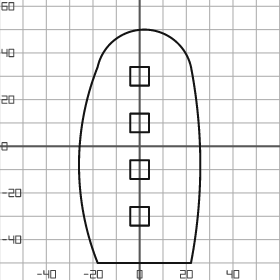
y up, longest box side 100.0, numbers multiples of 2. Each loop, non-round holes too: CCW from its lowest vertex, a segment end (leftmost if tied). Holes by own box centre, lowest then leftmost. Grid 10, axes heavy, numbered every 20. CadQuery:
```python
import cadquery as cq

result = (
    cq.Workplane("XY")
    .moveTo(-18.0, -50.0)
    .lineTo(22.0, -50.0)
    .threePointArc((26.0, -8.0), (22.0, 34.0))
    .threePointArc((2.0, 50.0), (-18.0, 34.0))
    .threePointArc((-26.0, -8.0), (-18.0, -50.0))
    .close()
    .moveTo(-4.0, -34.0)
    .lineTo(4.0, -34.0)
    .lineTo(4.0, -26.0)
    .lineTo(-4.0, -26.0)
    .close()
    .moveTo(-4.0, -14.0)
    .lineTo(4.0, -14.0)
    .lineTo(4.0, -6.0)
    .lineTo(-4.0, -6.0)
    .close()
    .moveTo(-4.0, 6.0)
    .lineTo(4.0, 6.0)
    .lineTo(4.0, 14.0)
    .lineTo(-4.0, 14.0)
    .close()
    .moveTo(-4.0, 26.0)
    .lineTo(4.0, 26.0)
    .lineTo(4.0, 34.0)
    .lineTo(-4.0, 34.0)
    .close()
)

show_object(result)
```